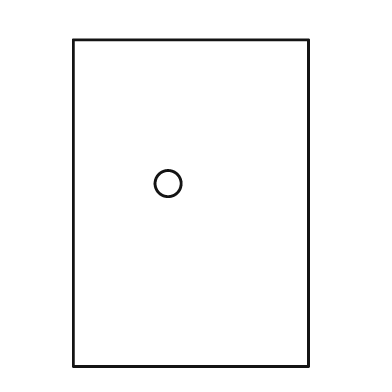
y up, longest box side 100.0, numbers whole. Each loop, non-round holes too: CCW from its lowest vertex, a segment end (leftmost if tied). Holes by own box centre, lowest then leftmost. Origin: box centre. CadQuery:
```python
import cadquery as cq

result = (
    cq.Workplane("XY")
    .moveTo(-36.0, -50.0)
    .lineTo(36.0, -50.0)
    .lineTo(36.0, 50.0)
    .lineTo(-36.0, 50.0)
    .close()
    .moveTo(-7.0, 6.0)
    .circle(4.0)
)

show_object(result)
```